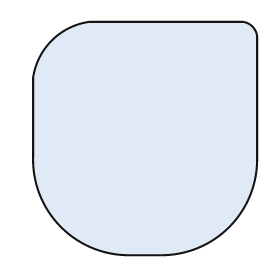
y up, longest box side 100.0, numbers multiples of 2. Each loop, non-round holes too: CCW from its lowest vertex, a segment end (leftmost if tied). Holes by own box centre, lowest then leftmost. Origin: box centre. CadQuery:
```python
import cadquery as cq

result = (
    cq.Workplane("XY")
    .moveTo(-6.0, -50.0)
    .lineTo(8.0, -50.0)
    .threePointArc((36.0, -38.0), (48.0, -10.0))
    .lineTo(48.0, 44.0)
    .threePointArc((46.0, 48.0), (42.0, 50.0))
    .lineTo(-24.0, 50.0)
    .threePointArc((-40.0, 42.0), (-48.0, 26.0))
    .lineTo(-48.0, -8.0)
    .threePointArc((-36.0, -38.0), (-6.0, -50.0))
    .close()
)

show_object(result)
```